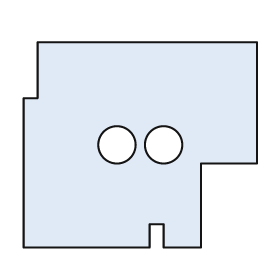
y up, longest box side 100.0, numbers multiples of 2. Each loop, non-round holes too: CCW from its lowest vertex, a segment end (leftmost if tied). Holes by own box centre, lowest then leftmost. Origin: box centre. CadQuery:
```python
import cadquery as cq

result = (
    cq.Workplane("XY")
    .moveTo(-50.0, -44.0)
    .lineTo(4.0, -44.0)
    .lineTo(4.0, -34.0)
    .lineTo(10.0, -34.0)
    .lineTo(10.0, -44.0)
    .lineTo(26.0, -44.0)
    .lineTo(26.0, -8.0)
    .lineTo(50.0, -8.0)
    .lineTo(50.0, 44.0)
    .lineTo(-44.0, 44.0)
    .lineTo(-44.0, 20.0)
    .lineTo(-50.0, 20.0)
    .close()
    .moveTo(-10.0, 0.0)
    .circle(8.0)
    .moveTo(10.0, 0.0)
    .circle(8.0)
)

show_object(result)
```